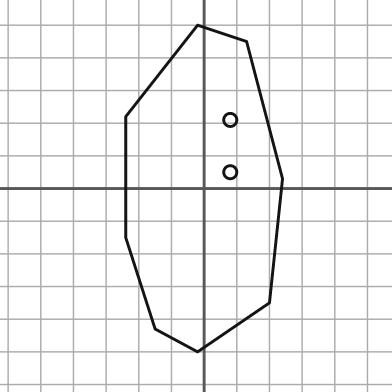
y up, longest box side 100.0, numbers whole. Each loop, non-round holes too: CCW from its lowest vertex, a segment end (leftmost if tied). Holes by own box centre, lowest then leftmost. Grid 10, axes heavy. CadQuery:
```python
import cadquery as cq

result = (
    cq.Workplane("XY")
    .moveTo(-2.0, -50.0)
    .lineTo(20.0, -35.0)
    .lineTo(24.0, 3.0)
    .lineTo(13.0, 45.0)
    .lineTo(-2.0, 50.0)
    .lineTo(-24.0, 22.0)
    .lineTo(-24.0, -15.0)
    .lineTo(-15.0, -43.0)
    .close()
    .moveTo(8.0, 5.0)
    .circle(2.0)
    .moveTo(8.0, 21.0)
    .circle(2.0)
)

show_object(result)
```